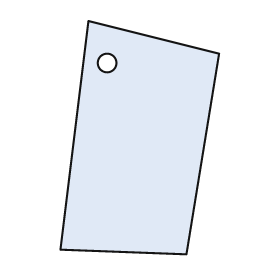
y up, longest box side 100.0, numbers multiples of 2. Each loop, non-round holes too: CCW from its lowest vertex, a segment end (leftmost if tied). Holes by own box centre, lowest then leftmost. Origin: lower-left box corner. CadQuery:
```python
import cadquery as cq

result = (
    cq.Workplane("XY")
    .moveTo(54.0, 0.0)
    .lineTo(68.0, 86.0)
    .lineTo(12.0, 100.0)
    .lineTo(0.0, 2.0)
    .close()
    .moveTo(20.0, 82.0)
    .circle(4.0)
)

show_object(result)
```